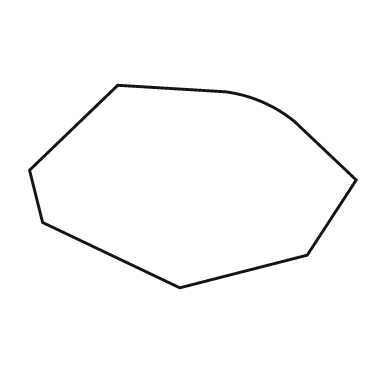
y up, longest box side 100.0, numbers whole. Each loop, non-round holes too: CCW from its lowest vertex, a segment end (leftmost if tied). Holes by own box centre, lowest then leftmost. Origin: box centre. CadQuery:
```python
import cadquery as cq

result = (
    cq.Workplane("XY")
    .moveTo(-4.0, -31.0)
    .lineTo(35.0, -21.0)
    .lineTo(50.0, 2.0)
    .lineTo(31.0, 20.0)
    .threePointArc((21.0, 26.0), (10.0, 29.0))
    .lineTo(-23.0, 31.0)
    .lineTo(-50.0, 5.0)
    .lineTo(-46.0, -11.0)
    .close()
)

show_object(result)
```